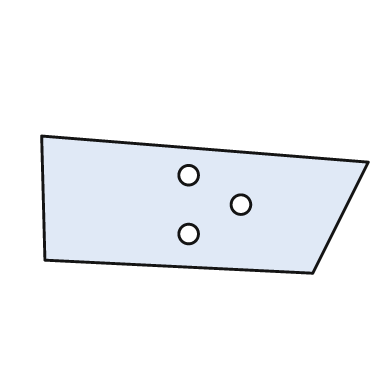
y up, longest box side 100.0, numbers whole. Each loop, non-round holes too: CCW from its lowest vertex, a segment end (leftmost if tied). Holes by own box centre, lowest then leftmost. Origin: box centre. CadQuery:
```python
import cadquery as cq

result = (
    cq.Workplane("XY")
    .moveTo(33.0, -21.0)
    .lineTo(50.0, 13.0)
    .lineTo(-50.0, 21.0)
    .lineTo(-49.0, -17.0)
    .close()
    .moveTo(-5.0, -9.0)
    .circle(3.0)
    .moveTo(11.0, 0.0)
    .circle(3.0)
    .moveTo(-5.0, 9.0)
    .circle(3.0)
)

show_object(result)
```